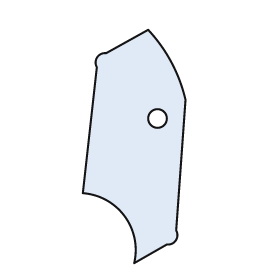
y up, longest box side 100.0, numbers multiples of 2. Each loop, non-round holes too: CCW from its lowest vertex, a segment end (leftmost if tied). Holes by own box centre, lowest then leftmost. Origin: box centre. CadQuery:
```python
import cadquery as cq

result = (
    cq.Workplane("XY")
    .moveTo(0.0, -50.0)
    .lineTo(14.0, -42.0)
    .threePointArc((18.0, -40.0), (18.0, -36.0))
    .lineTo(22.0, 20.0)
    .threePointArc((16.0, 36.0), (6.0, 50.0))
    .lineTo(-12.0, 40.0)
    .threePointArc((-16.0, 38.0), (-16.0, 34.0))
    .lineTo(-22.0, -20.0)
    .threePointArc((-4.0, -30.0), (0.0, -50.0))
    .close()
    .moveTo(10.0, 12.0)
    .circle(4.0)
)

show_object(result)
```